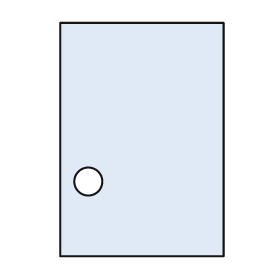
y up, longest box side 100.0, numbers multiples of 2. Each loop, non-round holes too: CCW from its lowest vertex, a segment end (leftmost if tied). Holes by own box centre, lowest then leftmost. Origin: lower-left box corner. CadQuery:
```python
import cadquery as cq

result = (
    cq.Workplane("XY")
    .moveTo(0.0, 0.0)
    .lineTo(70.0, 0.0)
    .lineTo(70.0, 100.0)
    .lineTo(0.0, 100.0)
    .close()
    .moveTo(12.0, 32.0)
    .circle(6.0)
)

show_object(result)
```